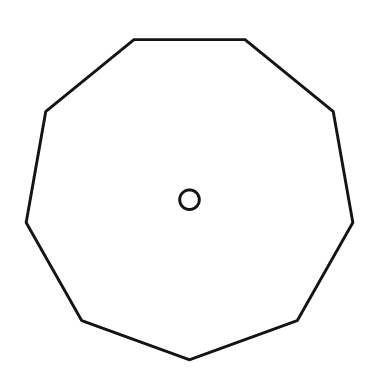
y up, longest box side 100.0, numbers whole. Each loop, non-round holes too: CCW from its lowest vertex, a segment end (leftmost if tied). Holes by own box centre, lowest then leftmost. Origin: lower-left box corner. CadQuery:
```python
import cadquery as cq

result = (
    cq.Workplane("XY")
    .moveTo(50.0, 0.0)
    .lineTo(83.0, 12.0)
    .lineTo(100.0, 42.0)
    .lineTo(94.0, 76.0)
    .lineTo(67.0, 98.0)
    .lineTo(33.0, 98.0)
    .lineTo(6.0, 76.0)
    .lineTo(0.0, 42.0)
    .lineTo(17.0, 12.0)
    .close()
    .moveTo(50.0, 49.0)
    .circle(3.0)
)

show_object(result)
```